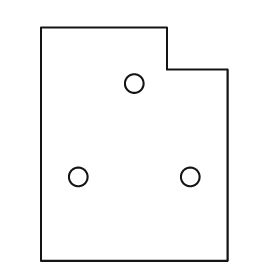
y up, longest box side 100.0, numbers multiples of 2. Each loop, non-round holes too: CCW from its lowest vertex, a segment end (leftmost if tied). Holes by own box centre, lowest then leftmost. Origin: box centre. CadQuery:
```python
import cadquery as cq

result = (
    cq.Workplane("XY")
    .moveTo(-40.0, -50.0)
    .lineTo(40.0, -50.0)
    .lineTo(40.0, 32.0)
    .lineTo(14.0, 32.0)
    .lineTo(14.0, 50.0)
    .lineTo(-40.0, 50.0)
    .close()
    .moveTo(-24.0, -14.0)
    .circle(4.0)
    .moveTo(24.0, -14.0)
    .circle(4.0)
    .moveTo(0.0, 26.0)
    .circle(4.0)
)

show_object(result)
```